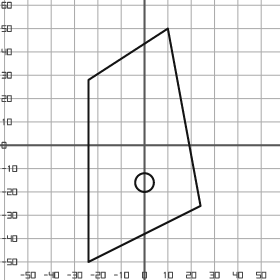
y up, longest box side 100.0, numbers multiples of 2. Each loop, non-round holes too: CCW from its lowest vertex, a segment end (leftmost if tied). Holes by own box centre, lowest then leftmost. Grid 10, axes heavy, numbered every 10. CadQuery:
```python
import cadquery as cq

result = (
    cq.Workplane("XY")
    .moveTo(-24.0, -50.0)
    .lineTo(24.0, -26.0)
    .lineTo(10.0, 50.0)
    .lineTo(-24.0, 28.0)
    .close()
    .moveTo(0.0, -16.0)
    .circle(4.0)
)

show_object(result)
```